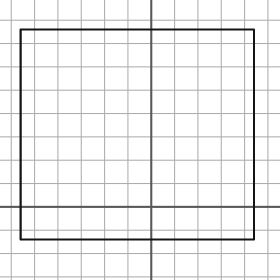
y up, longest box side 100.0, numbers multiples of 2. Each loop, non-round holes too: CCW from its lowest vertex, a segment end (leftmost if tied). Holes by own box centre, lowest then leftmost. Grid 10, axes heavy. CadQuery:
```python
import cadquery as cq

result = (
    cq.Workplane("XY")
    .moveTo(-56.0, -14.0)
    .lineTo(44.0, -14.0)
    .lineTo(44.0, 76.0)
    .lineTo(-56.0, 76.0)
    .close()
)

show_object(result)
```